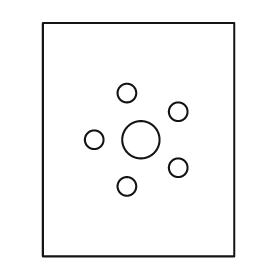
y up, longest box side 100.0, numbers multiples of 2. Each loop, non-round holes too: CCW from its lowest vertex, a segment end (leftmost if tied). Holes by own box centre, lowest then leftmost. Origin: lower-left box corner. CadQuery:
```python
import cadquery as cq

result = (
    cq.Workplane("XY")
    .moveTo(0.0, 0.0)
    .lineTo(82.0, 0.0)
    .lineTo(82.0, 100.0)
    .lineTo(0.0, 100.0)
    .close()
    .moveTo(36.0, 30.0)
    .circle(4.0)
    .moveTo(58.0, 38.0)
    .circle(4.0)
    .moveTo(22.0, 50.0)
    .circle(4.0)
    .moveTo(42.0, 50.0)
    .circle(8.0)
    .moveTo(58.0, 62.0)
    .circle(4.0)
    .moveTo(36.0, 70.0)
    .circle(4.0)
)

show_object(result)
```